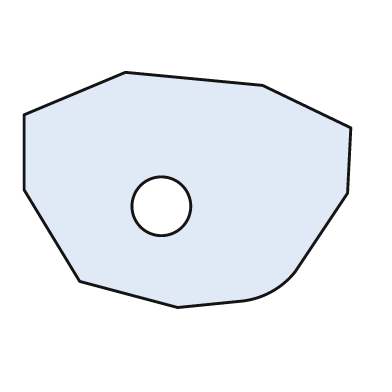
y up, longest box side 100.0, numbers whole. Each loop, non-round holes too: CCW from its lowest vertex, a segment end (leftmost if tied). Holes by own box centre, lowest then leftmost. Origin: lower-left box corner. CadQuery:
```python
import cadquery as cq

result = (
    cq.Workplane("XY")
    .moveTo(47.0, 0.0)
    .lineTo(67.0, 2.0)
    .threePointArc((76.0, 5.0), (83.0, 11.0))
    .lineTo(99.0, 35.0)
    .lineTo(100.0, 55.0)
    .lineTo(73.0, 68.0)
    .lineTo(31.0, 72.0)
    .lineTo(0.0, 59.0)
    .lineTo(0.0, 36.0)
    .lineTo(17.0, 8.0)
    .close()
    .moveTo(42.0, 31.0)
    .circle(9.0)
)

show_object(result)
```